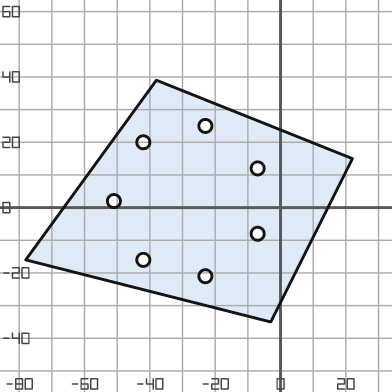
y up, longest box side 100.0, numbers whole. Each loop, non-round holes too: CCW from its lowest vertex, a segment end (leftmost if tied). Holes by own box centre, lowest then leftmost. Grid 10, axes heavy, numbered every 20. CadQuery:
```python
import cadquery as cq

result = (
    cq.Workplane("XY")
    .moveTo(-3.0, -35.0)
    .lineTo(22.0, 15.0)
    .lineTo(-38.0, 39.0)
    .lineTo(-78.0, -16.0)
    .close()
    .moveTo(-23.0, -21.0)
    .circle(2.0)
    .moveTo(-42.0, -16.0)
    .circle(2.0)
    .moveTo(-7.0, -8.0)
    .circle(2.0)
    .moveTo(-51.0, 2.0)
    .circle(2.0)
    .moveTo(-7.0, 12.0)
    .circle(2.0)
    .moveTo(-42.0, 20.0)
    .circle(2.0)
    .moveTo(-23.0, 25.0)
    .circle(2.0)
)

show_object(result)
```